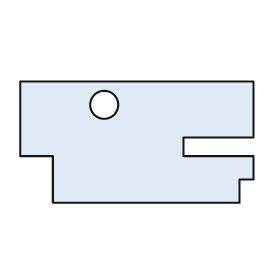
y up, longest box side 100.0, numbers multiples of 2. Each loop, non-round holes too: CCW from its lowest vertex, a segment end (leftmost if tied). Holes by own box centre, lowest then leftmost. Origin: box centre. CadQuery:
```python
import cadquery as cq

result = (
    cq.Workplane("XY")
    .moveTo(-36.0, -26.0)
    .lineTo(44.0, -26.0)
    .lineTo(44.0, -16.0)
    .lineTo(50.0, -16.0)
    .lineTo(50.0, -6.0)
    .lineTo(20.0, -6.0)
    .lineTo(20.0, 2.0)
    .lineTo(50.0, 2.0)
    .lineTo(50.0, 26.0)
    .lineTo(-50.0, 26.0)
    .lineTo(-50.0, -6.0)
    .lineTo(-36.0, -6.0)
    .close()
    .moveTo(-14.0, 16.0)
    .circle(6.0)
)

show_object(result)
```